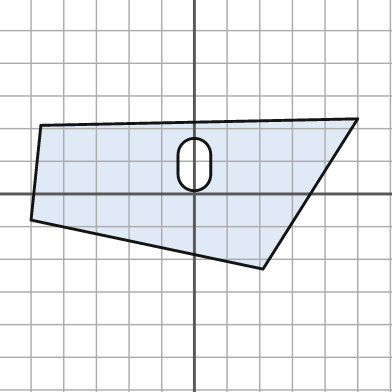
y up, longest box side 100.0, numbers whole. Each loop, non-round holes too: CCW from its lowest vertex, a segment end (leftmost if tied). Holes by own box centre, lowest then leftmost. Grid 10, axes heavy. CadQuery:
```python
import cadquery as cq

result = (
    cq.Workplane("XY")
    .moveTo(21.0, -23.0)
    .lineTo(50.0, 23.0)
    .lineTo(-47.0, 21.0)
    .lineTo(-50.0, -8.0)
    .close()
    .moveTo(-5.0, 6.0)
    .threePointArc((0.0, 1.0), (5.0, 6.0))
    .lineTo(5.0, 12.0)
    .threePointArc((0.0, 17.0), (-5.0, 12.0))
    .close()
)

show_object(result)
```